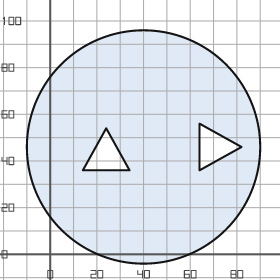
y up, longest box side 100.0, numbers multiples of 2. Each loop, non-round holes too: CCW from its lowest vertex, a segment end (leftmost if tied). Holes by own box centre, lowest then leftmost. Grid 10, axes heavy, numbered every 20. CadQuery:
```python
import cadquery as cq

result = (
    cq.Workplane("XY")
    .moveTo(40.0, 46.0)
    .circle(50.0)
    .moveTo(14.0, 36.0)
    .lineTo(34.0, 36.0)
    .lineTo(24.0, 54.0)
    .close()
    .moveTo(64.0, 36.0)
    .lineTo(82.0, 46.0)
    .lineTo(64.0, 56.0)
    .close()
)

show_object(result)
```